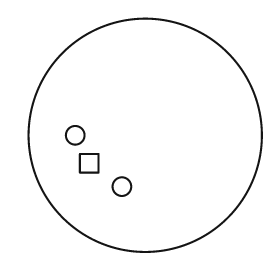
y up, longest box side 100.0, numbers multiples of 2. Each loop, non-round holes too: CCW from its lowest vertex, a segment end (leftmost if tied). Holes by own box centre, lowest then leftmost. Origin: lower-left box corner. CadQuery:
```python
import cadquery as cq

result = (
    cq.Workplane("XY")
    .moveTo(50.0, 50.0)
    .circle(50.0)
    .moveTo(40.0, 28.0)
    .circle(4.0)
    .moveTo(22.0, 34.0)
    .lineTo(30.0, 34.0)
    .lineTo(30.0, 42.0)
    .lineTo(22.0, 42.0)
    .close()
    .moveTo(20.0, 50.0)
    .circle(4.0)
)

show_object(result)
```